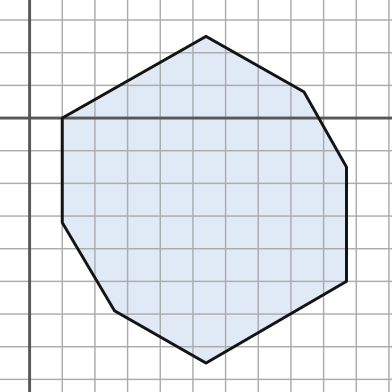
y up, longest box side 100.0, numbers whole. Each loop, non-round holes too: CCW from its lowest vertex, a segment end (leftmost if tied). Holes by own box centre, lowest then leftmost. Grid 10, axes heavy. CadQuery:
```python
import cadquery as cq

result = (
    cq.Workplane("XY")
    .moveTo(54.0, -75.0)
    .lineTo(97.0, -50.0)
    .lineTo(97.0, -15.0)
    .lineTo(84.0, 8.0)
    .lineTo(54.0, 25.0)
    .lineTo(10.0, 0.0)
    .lineTo(10.0, -32.0)
    .lineTo(26.0, -59.0)
    .close()
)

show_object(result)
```